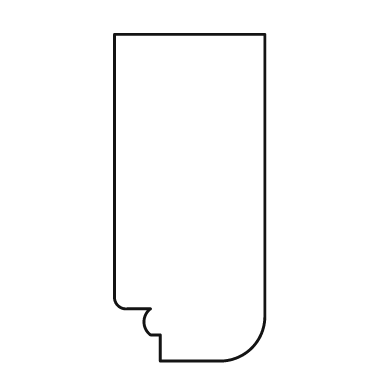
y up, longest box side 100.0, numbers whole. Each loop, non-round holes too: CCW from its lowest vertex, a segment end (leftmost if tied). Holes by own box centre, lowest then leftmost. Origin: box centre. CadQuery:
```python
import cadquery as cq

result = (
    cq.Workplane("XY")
    .moveTo(-9.0, -50.0)
    .lineTo(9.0, -50.0)
    .threePointArc((19.0, -46.0), (23.0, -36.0))
    .lineTo(23.0, 50.0)
    .lineTo(-23.0, 50.0)
    .lineTo(-23.0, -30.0)
    .threePointArc((-22.0, -33.0), (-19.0, -34.0))
    .lineTo(-12.0, -34.0)
    .threePointArc((-14.0, -38.0), (-12.0, -42.0))
    .lineTo(-9.0, -42.0)
    .close()
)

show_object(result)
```